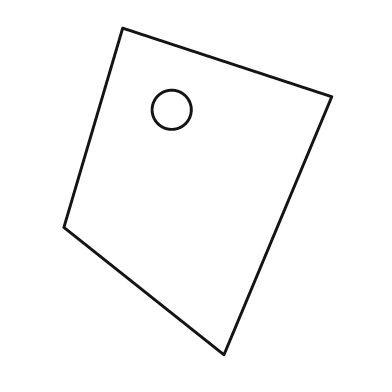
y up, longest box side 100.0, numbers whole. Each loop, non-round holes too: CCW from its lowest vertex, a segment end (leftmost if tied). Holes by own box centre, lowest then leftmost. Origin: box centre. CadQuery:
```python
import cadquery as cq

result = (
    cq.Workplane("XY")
    .moveTo(8.0, -50.0)
    .lineTo(41.0, 29.0)
    .lineTo(-23.0, 50.0)
    .lineTo(-41.0, -11.0)
    .close()
    .moveTo(-8.0, 25.0)
    .circle(6.0)
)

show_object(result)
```